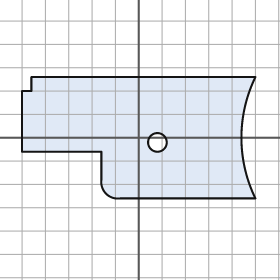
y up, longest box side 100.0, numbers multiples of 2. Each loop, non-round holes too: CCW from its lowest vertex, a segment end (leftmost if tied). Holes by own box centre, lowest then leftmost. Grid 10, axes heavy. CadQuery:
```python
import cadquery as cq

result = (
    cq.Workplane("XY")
    .moveTo(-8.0, -26.0)
    .lineTo(50.0, -26.0)
    .threePointArc((44.0, 0.0), (50.0, 26.0))
    .lineTo(-46.0, 26.0)
    .lineTo(-46.0, 20.0)
    .lineTo(-50.0, 20.0)
    .lineTo(-50.0, -6.0)
    .lineTo(-16.0, -6.0)
    .lineTo(-16.0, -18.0)
    .threePointArc((-14.0, -24.0), (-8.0, -26.0))
    .close()
    .moveTo(8.0, -2.0)
    .circle(4.0)
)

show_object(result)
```